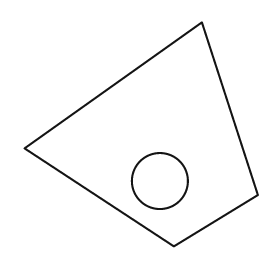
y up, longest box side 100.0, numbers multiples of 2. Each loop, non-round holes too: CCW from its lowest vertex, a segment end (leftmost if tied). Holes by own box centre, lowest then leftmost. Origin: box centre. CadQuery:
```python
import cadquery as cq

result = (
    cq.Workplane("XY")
    .moveTo(14.0, -48.0)
    .lineTo(50.0, -26.0)
    .lineTo(26.0, 48.0)
    .lineTo(-50.0, -6.0)
    .close()
    .moveTo(8.0, -20.0)
    .circle(12.0)
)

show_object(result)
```